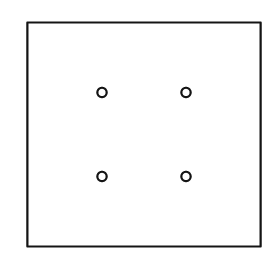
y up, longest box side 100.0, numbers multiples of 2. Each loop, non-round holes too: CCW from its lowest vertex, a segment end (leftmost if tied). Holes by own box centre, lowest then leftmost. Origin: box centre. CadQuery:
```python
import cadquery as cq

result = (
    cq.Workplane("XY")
    .moveTo(-50.0, -48.0)
    .lineTo(50.0, -48.0)
    .lineTo(50.0, 48.0)
    .lineTo(-50.0, 48.0)
    .close()
    .moveTo(-18.0, -18.0)
    .circle(2.0)
    .moveTo(18.0, -18.0)
    .circle(2.0)
    .moveTo(-18.0, 18.0)
    .circle(2.0)
    .moveTo(18.0, 18.0)
    .circle(2.0)
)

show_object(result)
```